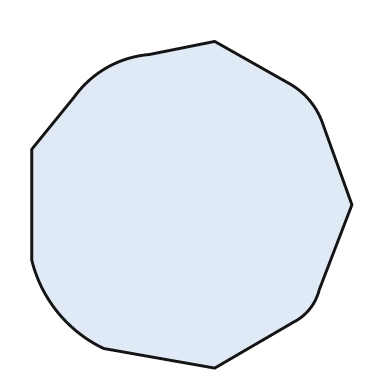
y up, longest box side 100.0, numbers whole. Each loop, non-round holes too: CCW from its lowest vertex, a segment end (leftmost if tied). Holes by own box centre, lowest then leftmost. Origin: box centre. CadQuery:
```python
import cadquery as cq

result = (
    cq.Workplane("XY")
    .moveTo(7.0, -50.0)
    .lineTo(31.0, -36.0)
    .threePointArc((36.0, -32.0), (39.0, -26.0))
    .lineTo(49.0, 0.0)
    .lineTo(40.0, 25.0)
    .threePointArc((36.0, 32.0), (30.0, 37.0))
    .lineTo(7.0, 50.0)
    .lineTo(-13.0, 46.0)
    .threePointArc((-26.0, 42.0), (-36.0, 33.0))
    .lineTo(-49.0, 17.0)
    .lineTo(-49.0, -17.0)
    .threePointArc((-41.0, -33.0), (-27.0, -44.0))
    .close()
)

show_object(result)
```